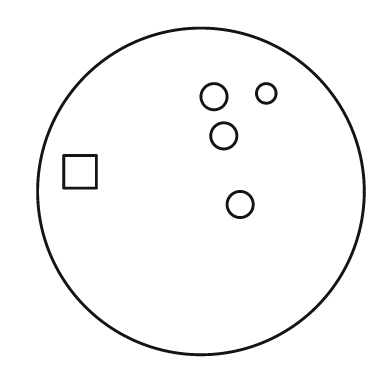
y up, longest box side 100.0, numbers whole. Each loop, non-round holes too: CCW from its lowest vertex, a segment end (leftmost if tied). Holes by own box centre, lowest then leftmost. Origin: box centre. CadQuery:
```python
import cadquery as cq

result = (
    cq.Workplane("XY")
    .moveTo(0.0, 0.0)
    .circle(50.0)
    .moveTo(12.0, -4.0)
    .circle(4.0)
    .moveTo(-42.0, 1.0)
    .lineTo(-32.0, 1.0)
    .lineTo(-32.0, 11.0)
    .lineTo(-42.0, 11.0)
    .close()
    .moveTo(7.0, 17.0)
    .circle(4.0)
    .moveTo(4.0, 29.0)
    .circle(4.0)
    .moveTo(20.0, 30.0)
    .circle(3.0)
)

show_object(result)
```